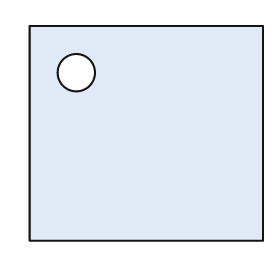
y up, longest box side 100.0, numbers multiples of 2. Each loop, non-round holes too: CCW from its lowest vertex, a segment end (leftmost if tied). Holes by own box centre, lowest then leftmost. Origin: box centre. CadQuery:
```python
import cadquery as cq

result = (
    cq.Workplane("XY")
    .moveTo(-50.0, -46.0)
    .lineTo(50.0, -46.0)
    .lineTo(50.0, 46.0)
    .lineTo(-50.0, 46.0)
    .close()
    .moveTo(-30.0, 26.0)
    .circle(8.0)
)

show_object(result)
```